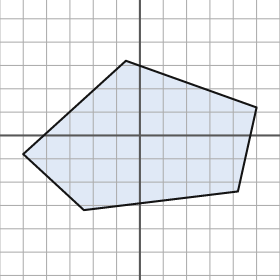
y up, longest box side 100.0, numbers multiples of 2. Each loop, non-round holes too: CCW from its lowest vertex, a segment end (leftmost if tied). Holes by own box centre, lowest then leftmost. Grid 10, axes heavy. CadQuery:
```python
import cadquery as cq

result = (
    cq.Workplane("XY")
    .moveTo(-24.0, -32.0)
    .lineTo(42.0, -24.0)
    .lineTo(50.0, 12.0)
    .lineTo(-6.0, 32.0)
    .lineTo(-50.0, -8.0)
    .close()
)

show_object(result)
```